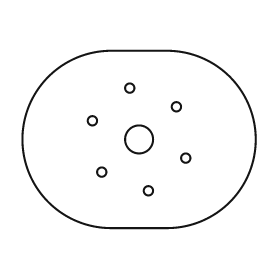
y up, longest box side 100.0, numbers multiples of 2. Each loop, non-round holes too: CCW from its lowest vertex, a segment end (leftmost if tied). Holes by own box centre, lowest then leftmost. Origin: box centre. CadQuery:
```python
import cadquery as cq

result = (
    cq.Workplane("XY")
    .moveTo(-12.0, -38.0)
    .lineTo(12.0, -38.0)
    .threePointArc((50.0, 0.0), (12.0, 38.0))
    .lineTo(-12.0, 38.0)
    .threePointArc((-50.0, 0.0), (-12.0, -38.0))
    .close()
    .moveTo(4.0, -22.0)
    .circle(2.0)
    .moveTo(-16.0, -14.0)
    .circle(2.0)
    .moveTo(20.0, -8.0)
    .circle(2.0)
    .moveTo(0.0, 0.0)
    .circle(6.0)
    .moveTo(-20.0, 8.0)
    .circle(2.0)
    .moveTo(16.0, 14.0)
    .circle(2.0)
    .moveTo(-4.0, 22.0)
    .circle(2.0)
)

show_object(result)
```